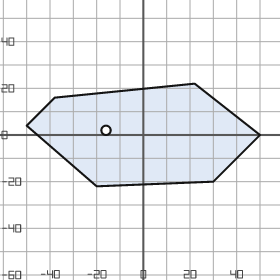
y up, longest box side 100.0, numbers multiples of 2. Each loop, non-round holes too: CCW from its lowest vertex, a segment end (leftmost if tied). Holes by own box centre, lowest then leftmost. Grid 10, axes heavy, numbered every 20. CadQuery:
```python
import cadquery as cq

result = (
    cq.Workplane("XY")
    .moveTo(-20.0, -22.0)
    .lineTo(30.0, -20.0)
    .lineTo(50.0, 0.0)
    .lineTo(22.0, 22.0)
    .lineTo(-38.0, 16.0)
    .lineTo(-50.0, 4.0)
    .close()
    .moveTo(-16.0, 2.0)
    .circle(2.0)
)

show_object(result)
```